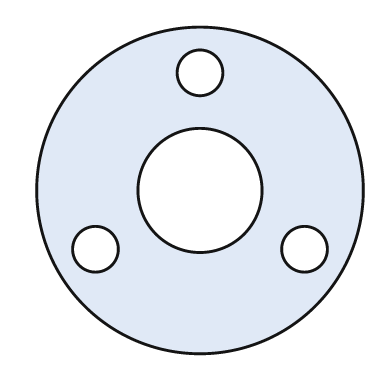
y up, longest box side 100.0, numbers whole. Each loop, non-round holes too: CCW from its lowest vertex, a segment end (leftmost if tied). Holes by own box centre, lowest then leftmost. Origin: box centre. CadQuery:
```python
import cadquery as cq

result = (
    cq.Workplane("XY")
    .moveTo(0.0, 0.0)
    .circle(50.0)
    .moveTo(-32.0, -18.0)
    .circle(7.0)
    .moveTo(32.0, -18.0)
    .circle(7.0)
    .moveTo(0.0, 0.0)
    .circle(19.0)
    .moveTo(0.0, 36.0)
    .circle(7.0)
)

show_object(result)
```